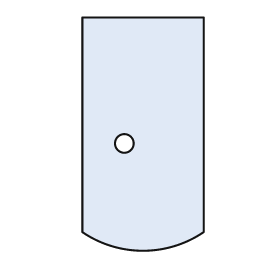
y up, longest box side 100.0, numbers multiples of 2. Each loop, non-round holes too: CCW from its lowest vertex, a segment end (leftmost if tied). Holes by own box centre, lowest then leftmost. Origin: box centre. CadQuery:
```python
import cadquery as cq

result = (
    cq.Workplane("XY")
    .moveTo(-26.0, -42.0)
    .threePointArc((0.0, -50.0), (26.0, -42.0))
    .lineTo(26.0, 50.0)
    .lineTo(-26.0, 50.0)
    .close()
    .moveTo(-8.0, -4.0)
    .circle(4.0)
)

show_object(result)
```